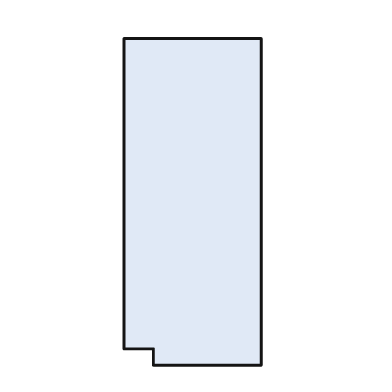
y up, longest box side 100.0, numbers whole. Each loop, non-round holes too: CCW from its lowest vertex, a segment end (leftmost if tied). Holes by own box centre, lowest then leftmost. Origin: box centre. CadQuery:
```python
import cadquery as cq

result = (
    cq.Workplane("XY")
    .moveTo(-12.0, -50.0)
    .lineTo(21.0, -50.0)
    .lineTo(21.0, 50.0)
    .lineTo(-21.0, 50.0)
    .lineTo(-21.0, -45.0)
    .lineTo(-12.0, -45.0)
    .close()
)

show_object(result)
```